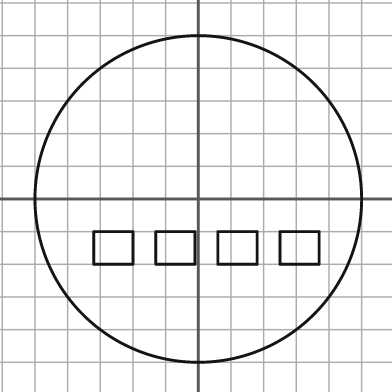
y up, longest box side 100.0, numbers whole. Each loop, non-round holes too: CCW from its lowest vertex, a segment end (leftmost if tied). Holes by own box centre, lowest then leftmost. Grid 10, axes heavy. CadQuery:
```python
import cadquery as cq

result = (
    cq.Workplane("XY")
    .moveTo(0.0, 0.0)
    .circle(50.0)
    .moveTo(-32.0, -20.0)
    .lineTo(-20.0, -20.0)
    .lineTo(-20.0, -10.0)
    .lineTo(-32.0, -10.0)
    .close()
    .moveTo(-13.0, -20.0)
    .lineTo(-1.0, -20.0)
    .lineTo(-1.0, -10.0)
    .lineTo(-13.0, -10.0)
    .close()
    .moveTo(6.0, -20.0)
    .lineTo(18.0, -20.0)
    .lineTo(18.0, -10.0)
    .lineTo(6.0, -10.0)
    .close()
    .moveTo(25.0, -20.0)
    .lineTo(37.0, -20.0)
    .lineTo(37.0, -10.0)
    .lineTo(25.0, -10.0)
    .close()
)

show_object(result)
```